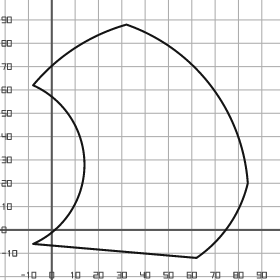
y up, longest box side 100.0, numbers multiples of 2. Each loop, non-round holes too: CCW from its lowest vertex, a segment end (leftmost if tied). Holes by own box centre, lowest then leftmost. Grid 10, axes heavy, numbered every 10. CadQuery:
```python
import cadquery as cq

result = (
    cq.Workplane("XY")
    .moveTo(62.0, -12.0)
    .threePointArc((76.0, 2.0), (84.0, 20.0))
    .threePointArc((68.0, 62.0), (32.0, 88.0))
    .threePointArc((10.0, 78.0), (-8.0, 62.0))
    .threePointArc((14.0, 28.0), (-8.0, -6.0))
    .close()
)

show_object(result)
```